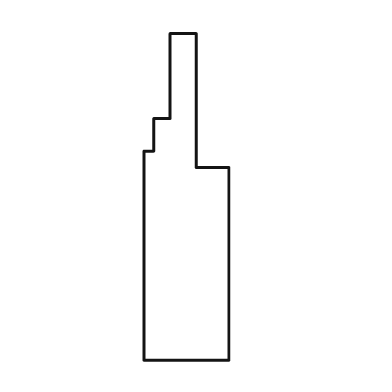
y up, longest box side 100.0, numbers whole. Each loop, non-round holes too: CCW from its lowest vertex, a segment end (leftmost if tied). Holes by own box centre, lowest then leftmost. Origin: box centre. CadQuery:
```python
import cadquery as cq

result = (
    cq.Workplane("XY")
    .moveTo(-13.0, -50.0)
    .lineTo(13.0, -50.0)
    .lineTo(13.0, 9.0)
    .lineTo(3.0, 9.0)
    .lineTo(3.0, 50.0)
    .lineTo(-5.0, 50.0)
    .lineTo(-5.0, 24.0)
    .lineTo(-10.0, 24.0)
    .lineTo(-10.0, 14.0)
    .lineTo(-13.0, 14.0)
    .close()
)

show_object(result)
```